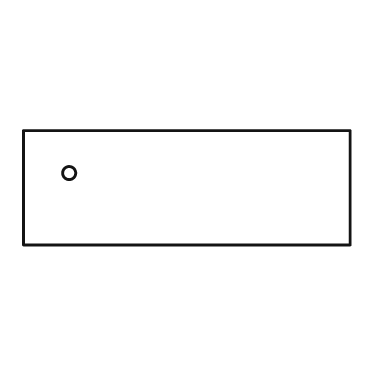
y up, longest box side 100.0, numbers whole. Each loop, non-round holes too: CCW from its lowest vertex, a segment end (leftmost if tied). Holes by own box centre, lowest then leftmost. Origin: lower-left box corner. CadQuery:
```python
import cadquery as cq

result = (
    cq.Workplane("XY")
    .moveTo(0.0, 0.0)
    .lineTo(100.0, 0.0)
    .lineTo(100.0, 35.0)
    .lineTo(0.0, 35.0)
    .close()
    .moveTo(14.0, 22.0)
    .circle(2.0)
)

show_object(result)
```